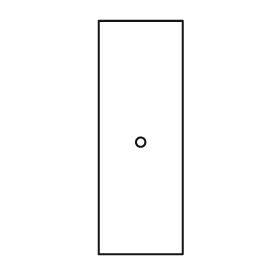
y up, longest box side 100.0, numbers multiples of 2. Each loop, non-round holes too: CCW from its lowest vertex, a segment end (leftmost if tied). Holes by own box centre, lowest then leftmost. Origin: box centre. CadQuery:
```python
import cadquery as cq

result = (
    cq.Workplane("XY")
    .moveTo(-18.0, -50.0)
    .lineTo(18.0, -50.0)
    .lineTo(18.0, 50.0)
    .lineTo(-18.0, 50.0)
    .close()
    .moveTo(0.0, -2.0)
    .circle(2.0)
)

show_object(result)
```